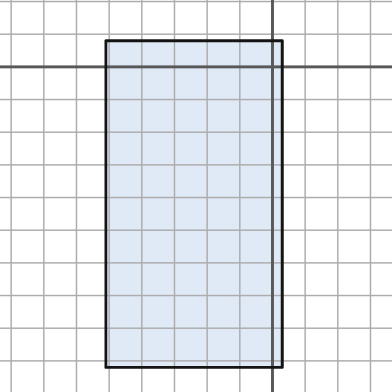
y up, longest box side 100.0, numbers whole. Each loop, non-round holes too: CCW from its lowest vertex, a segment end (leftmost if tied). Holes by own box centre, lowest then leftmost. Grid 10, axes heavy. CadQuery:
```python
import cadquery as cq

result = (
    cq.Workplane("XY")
    .moveTo(-51.0, -92.0)
    .lineTo(3.0, -92.0)
    .lineTo(3.0, 8.0)
    .lineTo(-51.0, 8.0)
    .close()
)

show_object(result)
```